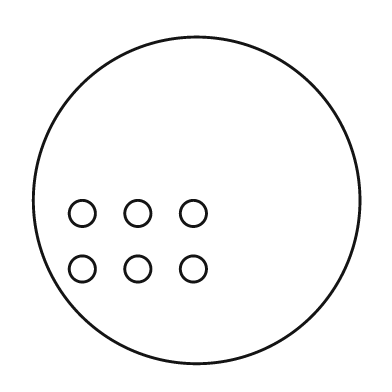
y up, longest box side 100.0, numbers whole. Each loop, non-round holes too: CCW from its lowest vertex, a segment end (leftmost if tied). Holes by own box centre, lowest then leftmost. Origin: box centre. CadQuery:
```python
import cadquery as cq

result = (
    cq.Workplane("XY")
    .moveTo(0.0, 0.0)
    .circle(50.0)
    .moveTo(-35.0, -21.0)
    .circle(4.0)
    .moveTo(-18.0, -21.0)
    .circle(4.0)
    .moveTo(-1.0, -21.0)
    .circle(4.0)
    .moveTo(-35.0, -4.0)
    .circle(4.0)
    .moveTo(-18.0, -4.0)
    .circle(4.0)
    .moveTo(-1.0, -4.0)
    .circle(4.0)
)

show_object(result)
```